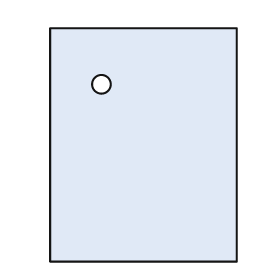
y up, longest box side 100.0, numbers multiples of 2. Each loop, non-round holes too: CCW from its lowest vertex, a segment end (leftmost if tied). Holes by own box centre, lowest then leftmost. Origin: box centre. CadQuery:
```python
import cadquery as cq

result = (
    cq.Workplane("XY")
    .moveTo(-40.0, -50.0)
    .lineTo(40.0, -50.0)
    .lineTo(40.0, 50.0)
    .lineTo(-40.0, 50.0)
    .close()
    .moveTo(-18.0, 26.0)
    .circle(4.0)
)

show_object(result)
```